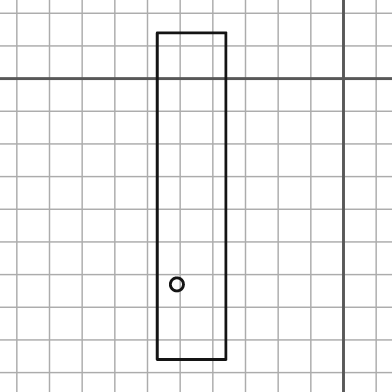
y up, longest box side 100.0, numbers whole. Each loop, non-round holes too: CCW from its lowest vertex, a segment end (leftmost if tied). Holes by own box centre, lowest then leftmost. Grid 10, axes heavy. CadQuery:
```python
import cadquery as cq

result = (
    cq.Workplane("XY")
    .moveTo(-57.0, -86.0)
    .lineTo(-36.0, -86.0)
    .lineTo(-36.0, 14.0)
    .lineTo(-57.0, 14.0)
    .close()
    .moveTo(-51.0, -63.0)
    .circle(2.0)
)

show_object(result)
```